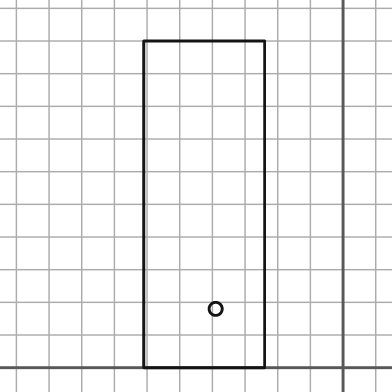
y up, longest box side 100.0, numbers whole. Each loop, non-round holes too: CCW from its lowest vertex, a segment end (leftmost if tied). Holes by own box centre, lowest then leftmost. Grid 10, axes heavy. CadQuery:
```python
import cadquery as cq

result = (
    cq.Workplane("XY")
    .moveTo(-61.0, 0.0)
    .lineTo(-24.0, 0.0)
    .lineTo(-24.0, 100.0)
    .lineTo(-61.0, 100.0)
    .close()
    .moveTo(-39.0, 18.0)
    .circle(2.0)
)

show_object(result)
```